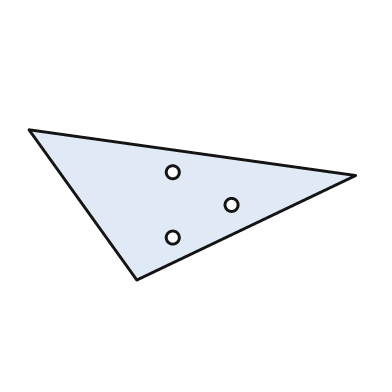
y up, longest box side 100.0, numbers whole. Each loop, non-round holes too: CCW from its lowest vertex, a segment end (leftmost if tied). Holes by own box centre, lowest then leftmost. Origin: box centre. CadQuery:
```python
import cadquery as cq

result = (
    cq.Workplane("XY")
    .moveTo(-17.0, -23.0)
    .lineTo(50.0, 9.0)
    .lineTo(-50.0, 23.0)
    .close()
    .moveTo(-6.0, -10.0)
    .circle(2.0)
    .moveTo(12.0, 0.0)
    .circle(2.0)
    .moveTo(-6.0, 10.0)
    .circle(2.0)
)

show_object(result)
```